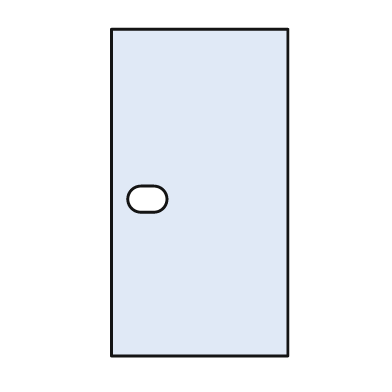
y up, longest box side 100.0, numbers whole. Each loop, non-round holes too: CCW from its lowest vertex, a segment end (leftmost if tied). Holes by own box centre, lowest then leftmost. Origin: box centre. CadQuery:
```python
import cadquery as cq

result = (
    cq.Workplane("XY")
    .moveTo(-27.0, -50.0)
    .lineTo(27.0, -50.0)
    .lineTo(27.0, 50.0)
    .lineTo(-27.0, 50.0)
    .close()
    .moveTo(-18.0, -6.0)
    .lineTo(-14.0, -6.0)
    .threePointArc((-10.0, -2.0), (-14.0, 2.0))
    .lineTo(-18.0, 2.0)
    .threePointArc((-22.0, -2.0), (-18.0, -6.0))
    .close()
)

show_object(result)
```